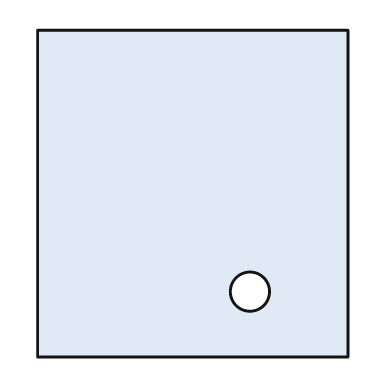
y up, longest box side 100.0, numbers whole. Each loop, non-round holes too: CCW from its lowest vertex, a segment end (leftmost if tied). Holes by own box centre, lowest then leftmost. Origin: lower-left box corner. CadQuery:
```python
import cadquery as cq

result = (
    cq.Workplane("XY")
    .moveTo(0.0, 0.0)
    .lineTo(95.0, 0.0)
    .lineTo(95.0, 100.0)
    .lineTo(0.0, 100.0)
    .close()
    .moveTo(65.0, 20.0)
    .circle(6.0)
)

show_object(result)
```